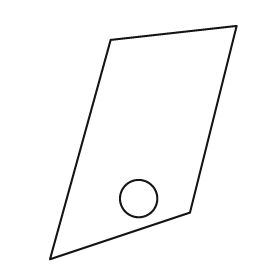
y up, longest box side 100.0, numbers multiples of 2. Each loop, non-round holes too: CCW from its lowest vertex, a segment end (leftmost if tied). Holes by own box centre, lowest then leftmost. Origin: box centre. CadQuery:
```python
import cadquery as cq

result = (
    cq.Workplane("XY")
    .moveTo(-40.0, -50.0)
    .lineTo(20.0, -30.0)
    .lineTo(40.0, 50.0)
    .lineTo(-14.0, 44.0)
    .close()
    .moveTo(-2.0, -24.0)
    .circle(8.0)
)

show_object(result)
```